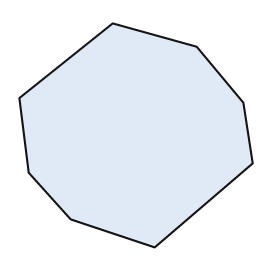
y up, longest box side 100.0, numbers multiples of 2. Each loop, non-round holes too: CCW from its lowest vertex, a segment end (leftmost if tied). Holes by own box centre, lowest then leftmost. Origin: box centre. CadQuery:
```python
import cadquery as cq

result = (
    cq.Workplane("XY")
    .moveTo(8.0, -48.0)
    .lineTo(50.0, -12.0)
    .lineTo(46.0, 14.0)
    .lineTo(26.0, 38.0)
    .lineTo(-10.0, 48.0)
    .lineTo(-50.0, 16.0)
    .lineTo(-46.0, -16.0)
    .lineTo(-28.0, -36.0)
    .close()
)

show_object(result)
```